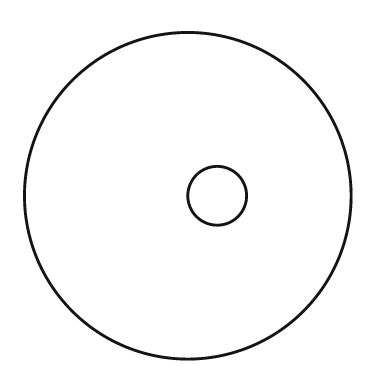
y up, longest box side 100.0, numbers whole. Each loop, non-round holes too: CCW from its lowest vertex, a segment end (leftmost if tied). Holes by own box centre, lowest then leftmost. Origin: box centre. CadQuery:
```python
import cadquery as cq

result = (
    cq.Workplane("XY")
    .moveTo(0.0, 0.0)
    .circle(50.0)
    .moveTo(9.0, 0.0)
    .circle(9.0)
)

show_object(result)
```